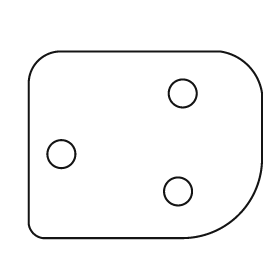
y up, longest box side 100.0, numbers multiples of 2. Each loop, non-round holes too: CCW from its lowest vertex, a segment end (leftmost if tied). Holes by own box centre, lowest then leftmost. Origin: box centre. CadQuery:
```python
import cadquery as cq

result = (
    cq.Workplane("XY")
    .moveTo(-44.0, -40.0)
    .lineTo(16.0, -40.0)
    .threePointArc((40.0, -30.0), (50.0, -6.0))
    .lineTo(50.0, 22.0)
    .threePointArc((44.0, 34.0), (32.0, 40.0))
    .lineTo(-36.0, 40.0)
    .threePointArc((-46.0, 36.0), (-50.0, 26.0))
    .lineTo(-50.0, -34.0)
    .threePointArc((-48.0, -38.0), (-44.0, -40.0))
    .close()
    .moveTo(14.0, -20.0)
    .circle(6.0)
    .moveTo(-36.0, -4.0)
    .circle(6.0)
    .moveTo(16.0, 22.0)
    .circle(6.0)
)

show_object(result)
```